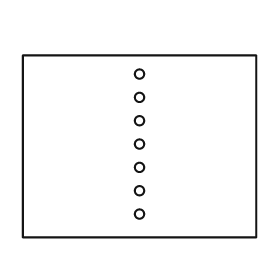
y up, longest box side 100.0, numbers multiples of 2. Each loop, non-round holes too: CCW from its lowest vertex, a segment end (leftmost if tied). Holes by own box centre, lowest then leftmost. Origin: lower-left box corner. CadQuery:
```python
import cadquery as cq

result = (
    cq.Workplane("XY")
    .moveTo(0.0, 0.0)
    .lineTo(100.0, 0.0)
    .lineTo(100.0, 78.0)
    .lineTo(0.0, 78.0)
    .close()
    .moveTo(50.0, 10.0)
    .circle(2.0)
    .moveTo(50.0, 20.0)
    .circle(2.0)
    .moveTo(50.0, 30.0)
    .circle(2.0)
    .moveTo(50.0, 40.0)
    .circle(2.0)
    .moveTo(50.0, 50.0)
    .circle(2.0)
    .moveTo(50.0, 60.0)
    .circle(2.0)
    .moveTo(50.0, 70.0)
    .circle(2.0)
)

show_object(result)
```